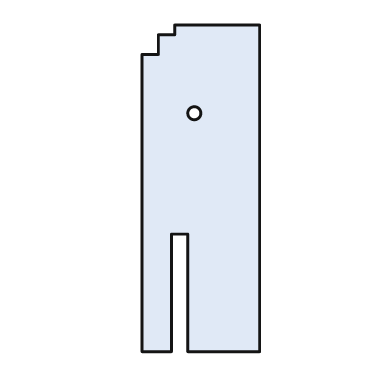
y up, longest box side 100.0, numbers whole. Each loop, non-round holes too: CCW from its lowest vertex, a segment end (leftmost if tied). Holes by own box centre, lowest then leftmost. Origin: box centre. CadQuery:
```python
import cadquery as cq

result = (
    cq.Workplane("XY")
    .moveTo(-18.0, -50.0)
    .lineTo(-9.0, -50.0)
    .lineTo(-9.0, -14.0)
    .lineTo(-4.0, -14.0)
    .lineTo(-4.0, -50.0)
    .lineTo(18.0, -50.0)
    .lineTo(18.0, 50.0)
    .lineTo(-8.0, 50.0)
    .lineTo(-8.0, 47.0)
    .lineTo(-13.0, 47.0)
    .lineTo(-13.0, 41.0)
    .lineTo(-18.0, 41.0)
    .close()
    .moveTo(-2.0, 23.0)
    .circle(2.0)
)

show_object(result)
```